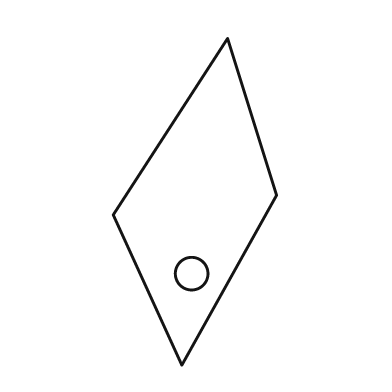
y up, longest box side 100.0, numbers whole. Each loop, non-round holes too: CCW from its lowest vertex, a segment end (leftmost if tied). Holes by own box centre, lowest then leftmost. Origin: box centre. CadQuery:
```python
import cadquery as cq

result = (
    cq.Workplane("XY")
    .moveTo(-4.0, -50.0)
    .lineTo(25.0, 2.0)
    .lineTo(10.0, 50.0)
    .lineTo(-25.0, -4.0)
    .close()
    .moveTo(-1.0, -22.0)
    .circle(5.0)
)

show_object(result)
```